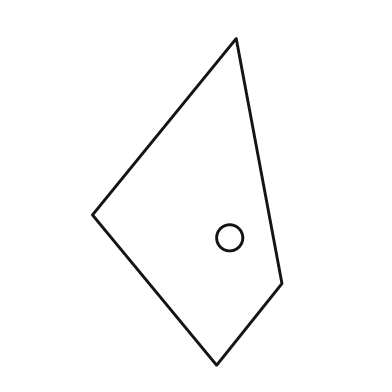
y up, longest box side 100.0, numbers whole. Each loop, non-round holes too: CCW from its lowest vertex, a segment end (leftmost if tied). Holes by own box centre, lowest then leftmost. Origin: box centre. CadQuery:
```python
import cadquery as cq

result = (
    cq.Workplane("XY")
    .moveTo(9.0, -50.0)
    .lineTo(29.0, -25.0)
    .lineTo(15.0, 50.0)
    .lineTo(-29.0, -4.0)
    .close()
    .moveTo(13.0, -11.0)
    .circle(4.0)
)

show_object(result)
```